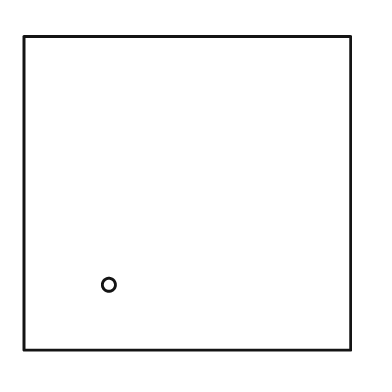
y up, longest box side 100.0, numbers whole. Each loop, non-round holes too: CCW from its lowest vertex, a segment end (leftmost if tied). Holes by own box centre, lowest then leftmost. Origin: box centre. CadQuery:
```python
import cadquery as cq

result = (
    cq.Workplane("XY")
    .moveTo(-50.0, -48.0)
    .lineTo(50.0, -48.0)
    .lineTo(50.0, 48.0)
    .lineTo(-50.0, 48.0)
    .close()
    .moveTo(-24.0, -28.0)
    .circle(2.0)
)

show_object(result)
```